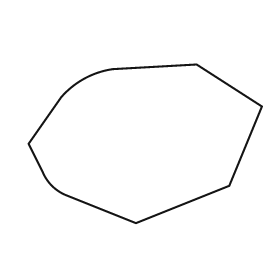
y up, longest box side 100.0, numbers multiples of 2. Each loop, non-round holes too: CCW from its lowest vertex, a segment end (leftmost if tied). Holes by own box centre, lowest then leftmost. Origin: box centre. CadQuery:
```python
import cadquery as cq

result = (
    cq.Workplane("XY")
    .moveTo(-4.0, -34.0)
    .lineTo(36.0, -18.0)
    .lineTo(50.0, 16.0)
    .lineTo(22.0, 34.0)
    .lineTo(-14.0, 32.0)
    .threePointArc((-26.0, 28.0), (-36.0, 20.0))
    .lineTo(-50.0, 0.0)
    .lineTo(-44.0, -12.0)
    .threePointArc((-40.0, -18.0), (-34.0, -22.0))
    .close()
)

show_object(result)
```